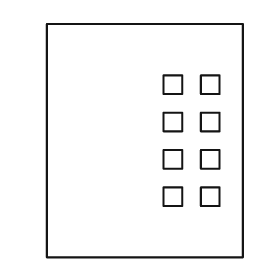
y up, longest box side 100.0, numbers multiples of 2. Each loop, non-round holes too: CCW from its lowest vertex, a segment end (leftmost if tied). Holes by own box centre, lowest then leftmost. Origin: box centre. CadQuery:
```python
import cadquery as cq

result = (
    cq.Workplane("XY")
    .moveTo(-42.0, -50.0)
    .lineTo(42.0, -50.0)
    .lineTo(42.0, 50.0)
    .lineTo(-42.0, 50.0)
    .close()
    .moveTo(8.0, -28.0)
    .lineTo(16.0, -28.0)
    .lineTo(16.0, -20.0)
    .lineTo(8.0, -20.0)
    .close()
    .moveTo(24.0, -28.0)
    .lineTo(32.0, -28.0)
    .lineTo(32.0, -20.0)
    .lineTo(24.0, -20.0)
    .close()
    .moveTo(8.0, -12.0)
    .lineTo(16.0, -12.0)
    .lineTo(16.0, -4.0)
    .lineTo(8.0, -4.0)
    .close()
    .moveTo(24.0, -12.0)
    .lineTo(32.0, -12.0)
    .lineTo(32.0, -4.0)
    .lineTo(24.0, -4.0)
    .close()
    .moveTo(8.0, 4.0)
    .lineTo(16.0, 4.0)
    .lineTo(16.0, 12.0)
    .lineTo(8.0, 12.0)
    .close()
    .moveTo(24.0, 4.0)
    .lineTo(32.0, 4.0)
    .lineTo(32.0, 12.0)
    .lineTo(24.0, 12.0)
    .close()
    .moveTo(8.0, 20.0)
    .lineTo(16.0, 20.0)
    .lineTo(16.0, 28.0)
    .lineTo(8.0, 28.0)
    .close()
    .moveTo(24.0, 20.0)
    .lineTo(32.0, 20.0)
    .lineTo(32.0, 28.0)
    .lineTo(24.0, 28.0)
    .close()
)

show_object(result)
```